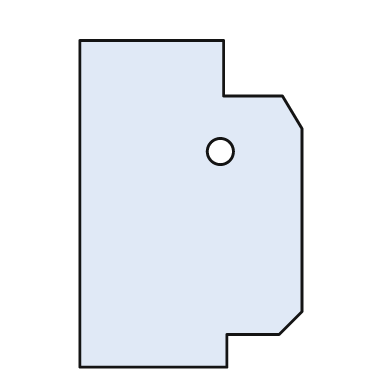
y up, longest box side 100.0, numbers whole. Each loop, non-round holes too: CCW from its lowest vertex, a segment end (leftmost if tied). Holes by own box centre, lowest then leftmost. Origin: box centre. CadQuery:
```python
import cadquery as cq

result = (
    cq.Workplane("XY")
    .moveTo(-34.0, -50.0)
    .lineTo(11.0, -50.0)
    .lineTo(11.0, -40.0)
    .lineTo(27.0, -40.0)
    .lineTo(34.0, -33.0)
    .lineTo(34.0, 23.0)
    .lineTo(28.0, 33.0)
    .lineTo(10.0, 33.0)
    .lineTo(10.0, 50.0)
    .lineTo(-34.0, 50.0)
    .close()
    .moveTo(9.0, 16.0)
    .circle(4.0)
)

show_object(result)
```